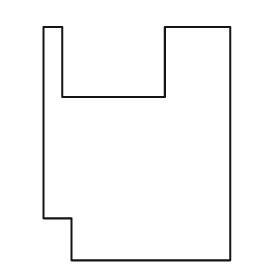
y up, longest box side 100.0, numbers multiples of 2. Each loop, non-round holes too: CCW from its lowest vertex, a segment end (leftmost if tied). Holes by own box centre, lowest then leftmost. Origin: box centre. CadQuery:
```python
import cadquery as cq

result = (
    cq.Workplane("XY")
    .moveTo(-28.0, -50.0)
    .lineTo(40.0, -50.0)
    .lineTo(40.0, 50.0)
    .lineTo(12.0, 50.0)
    .lineTo(12.0, 20.0)
    .lineTo(-32.0, 20.0)
    .lineTo(-32.0, 50.0)
    .lineTo(-40.0, 50.0)
    .lineTo(-40.0, -32.0)
    .lineTo(-28.0, -32.0)
    .close()
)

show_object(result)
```